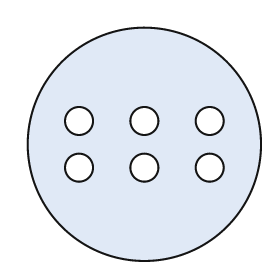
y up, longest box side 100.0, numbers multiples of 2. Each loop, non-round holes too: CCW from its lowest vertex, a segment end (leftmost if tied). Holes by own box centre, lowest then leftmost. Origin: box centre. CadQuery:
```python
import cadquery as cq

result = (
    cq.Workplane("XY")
    .moveTo(0.0, 0.0)
    .circle(50.0)
    .moveTo(-28.0, -10.0)
    .circle(6.0)
    .moveTo(0.0, -10.0)
    .circle(6.0)
    .moveTo(28.0, -10.0)
    .circle(6.0)
    .moveTo(-28.0, 10.0)
    .circle(6.0)
    .moveTo(0.0, 10.0)
    .circle(6.0)
    .moveTo(28.0, 10.0)
    .circle(6.0)
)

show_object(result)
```